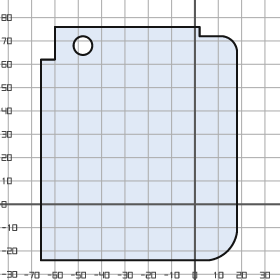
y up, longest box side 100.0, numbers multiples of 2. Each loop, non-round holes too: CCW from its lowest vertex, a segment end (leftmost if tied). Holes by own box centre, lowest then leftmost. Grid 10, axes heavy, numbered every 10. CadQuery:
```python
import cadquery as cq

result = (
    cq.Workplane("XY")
    .moveTo(-66.0, -24.0)
    .lineTo(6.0, -24.0)
    .threePointArc((14.0, -20.0), (18.0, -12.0))
    .lineTo(18.0, 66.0)
    .threePointArc((16.0, 70.0), (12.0, 72.0))
    .lineTo(2.0, 72.0)
    .lineTo(2.0, 76.0)
    .lineTo(-60.0, 76.0)
    .lineTo(-60.0, 62.0)
    .lineTo(-66.0, 62.0)
    .close()
    .moveTo(-48.0, 68.0)
    .circle(4.0)
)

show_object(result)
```